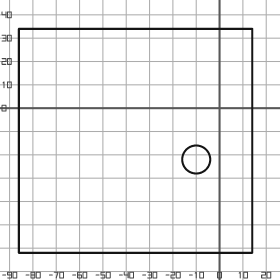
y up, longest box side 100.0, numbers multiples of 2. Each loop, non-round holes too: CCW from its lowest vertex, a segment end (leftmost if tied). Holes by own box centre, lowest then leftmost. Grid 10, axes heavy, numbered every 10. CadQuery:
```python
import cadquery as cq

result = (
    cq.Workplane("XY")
    .moveTo(-86.0, -62.0)
    .lineTo(14.0, -62.0)
    .lineTo(14.0, 34.0)
    .lineTo(-86.0, 34.0)
    .close()
    .moveTo(-10.0, -22.0)
    .circle(6.0)
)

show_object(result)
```